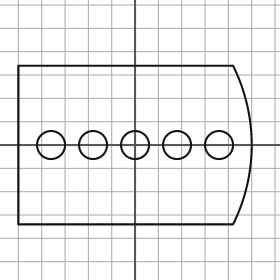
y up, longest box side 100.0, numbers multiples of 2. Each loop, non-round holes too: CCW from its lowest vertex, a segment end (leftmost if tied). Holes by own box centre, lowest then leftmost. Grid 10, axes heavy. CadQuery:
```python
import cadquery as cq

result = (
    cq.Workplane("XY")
    .moveTo(-50.0, -34.0)
    .lineTo(42.0, -34.0)
    .threePointArc((50.0, 0.0), (42.0, 34.0))
    .lineTo(-50.0, 34.0)
    .close()
    .moveTo(-36.0, 0.0)
    .circle(6.0)
    .moveTo(-18.0, 0.0)
    .circle(6.0)
    .moveTo(0.0, 0.0)
    .circle(6.0)
    .moveTo(18.0, 0.0)
    .circle(6.0)
    .moveTo(36.0, 0.0)
    .circle(6.0)
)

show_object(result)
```